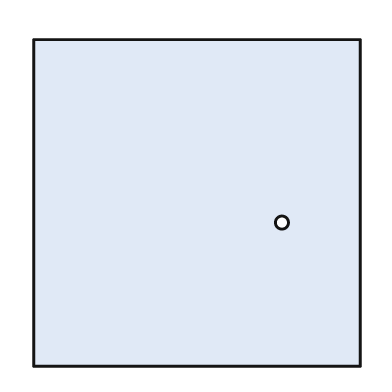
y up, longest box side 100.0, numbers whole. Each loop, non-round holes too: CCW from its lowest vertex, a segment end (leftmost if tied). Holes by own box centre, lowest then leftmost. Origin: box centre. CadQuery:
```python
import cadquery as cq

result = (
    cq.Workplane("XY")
    .moveTo(-50.0, -50.0)
    .lineTo(50.0, -50.0)
    .lineTo(50.0, 50.0)
    .lineTo(-50.0, 50.0)
    .close()
    .moveTo(26.0, -6.0)
    .circle(2.0)
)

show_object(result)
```